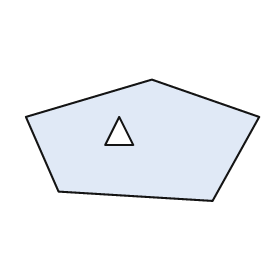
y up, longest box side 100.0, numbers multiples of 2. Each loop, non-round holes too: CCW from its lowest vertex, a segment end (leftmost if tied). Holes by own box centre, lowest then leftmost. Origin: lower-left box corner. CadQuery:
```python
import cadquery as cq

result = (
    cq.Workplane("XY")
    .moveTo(80.0, 0.0)
    .lineTo(100.0, 36.0)
    .lineTo(54.0, 52.0)
    .lineTo(0.0, 36.0)
    .lineTo(14.0, 4.0)
    .close()
    .moveTo(34.0, 24.0)
    .lineTo(46.0, 24.0)
    .lineTo(40.0, 36.0)
    .close()
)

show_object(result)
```